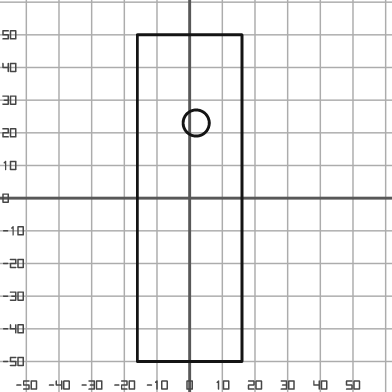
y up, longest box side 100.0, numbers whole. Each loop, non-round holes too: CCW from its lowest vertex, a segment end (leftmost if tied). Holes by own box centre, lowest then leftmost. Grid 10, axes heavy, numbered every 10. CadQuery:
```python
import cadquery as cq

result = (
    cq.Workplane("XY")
    .moveTo(-16.0, -50.0)
    .lineTo(16.0, -50.0)
    .lineTo(16.0, 50.0)
    .lineTo(-16.0, 50.0)
    .close()
    .moveTo(2.0, 23.0)
    .circle(4.0)
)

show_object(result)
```